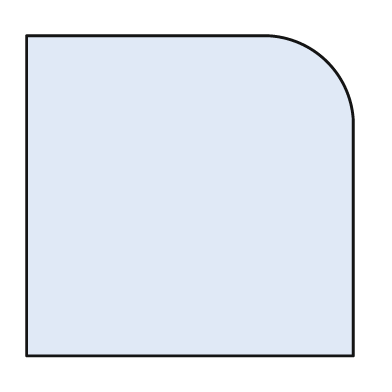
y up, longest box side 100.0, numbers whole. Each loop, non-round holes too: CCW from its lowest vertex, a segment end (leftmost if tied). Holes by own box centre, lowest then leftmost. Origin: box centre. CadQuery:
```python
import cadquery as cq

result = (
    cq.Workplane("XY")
    .moveTo(-50.0, -49.0)
    .lineTo(50.0, -49.0)
    .lineTo(50.0, 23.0)
    .threePointArc((42.0, 41.0), (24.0, 49.0))
    .lineTo(-50.0, 49.0)
    .close()
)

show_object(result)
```